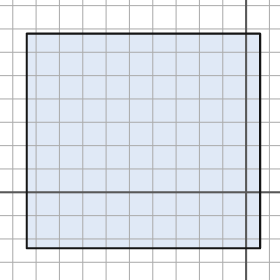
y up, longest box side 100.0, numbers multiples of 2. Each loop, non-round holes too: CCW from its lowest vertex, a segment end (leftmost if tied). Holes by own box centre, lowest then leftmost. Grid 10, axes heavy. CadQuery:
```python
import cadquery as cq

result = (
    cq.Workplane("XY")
    .moveTo(-94.0, -24.0)
    .lineTo(6.0, -24.0)
    .lineTo(6.0, 68.0)
    .lineTo(-94.0, 68.0)
    .close()
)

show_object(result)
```